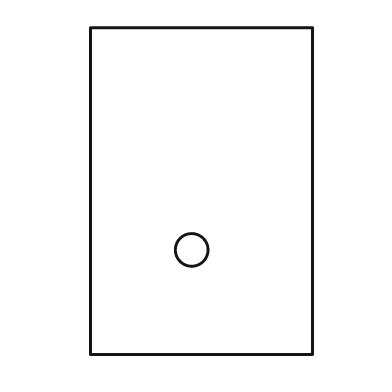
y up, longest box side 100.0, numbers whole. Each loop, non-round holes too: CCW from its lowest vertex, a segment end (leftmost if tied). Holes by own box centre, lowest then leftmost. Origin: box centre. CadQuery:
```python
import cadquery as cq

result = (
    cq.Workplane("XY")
    .moveTo(-34.0, -50.0)
    .lineTo(34.0, -50.0)
    .lineTo(34.0, 50.0)
    .lineTo(-34.0, 50.0)
    .close()
    .moveTo(-3.0, -18.0)
    .circle(5.0)
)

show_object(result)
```